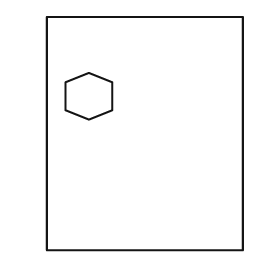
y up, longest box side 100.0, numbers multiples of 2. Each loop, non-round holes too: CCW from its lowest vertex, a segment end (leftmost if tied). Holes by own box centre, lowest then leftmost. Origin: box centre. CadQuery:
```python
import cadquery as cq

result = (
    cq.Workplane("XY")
    .moveTo(-42.0, -50.0)
    .lineTo(42.0, -50.0)
    .lineTo(42.0, 50.0)
    .lineTo(-42.0, 50.0)
    .close()
    .moveTo(-24.0, 6.0)
    .lineTo(-14.0, 10.0)
    .lineTo(-14.0, 22.0)
    .lineTo(-24.0, 26.0)
    .lineTo(-34.0, 22.0)
    .lineTo(-34.0, 10.0)
    .close()
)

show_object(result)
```